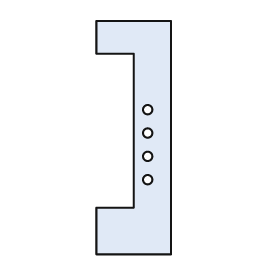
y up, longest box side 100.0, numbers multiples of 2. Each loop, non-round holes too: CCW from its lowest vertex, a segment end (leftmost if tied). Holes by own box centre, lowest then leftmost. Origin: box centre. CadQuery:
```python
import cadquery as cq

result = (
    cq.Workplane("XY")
    .moveTo(-16.0, -50.0)
    .lineTo(16.0, -50.0)
    .lineTo(16.0, 50.0)
    .lineTo(-16.0, 50.0)
    .lineTo(-16.0, 36.0)
    .lineTo(0.0, 36.0)
    .lineTo(0.0, -30.0)
    .lineTo(-16.0, -30.0)
    .close()
    .moveTo(6.0, -18.0)
    .circle(2.0)
    .moveTo(6.0, -8.0)
    .circle(2.0)
    .moveTo(6.0, 2.0)
    .circle(2.0)
    .moveTo(6.0, 12.0)
    .circle(2.0)
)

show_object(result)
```